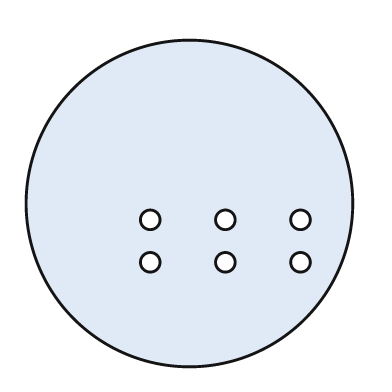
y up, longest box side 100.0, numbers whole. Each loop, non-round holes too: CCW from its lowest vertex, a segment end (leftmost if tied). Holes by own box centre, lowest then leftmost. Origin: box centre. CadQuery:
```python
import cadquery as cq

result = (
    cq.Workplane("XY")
    .moveTo(0.0, 0.0)
    .circle(50.0)
    .moveTo(-12.0, -18.0)
    .circle(3.0)
    .moveTo(11.0, -18.0)
    .circle(3.0)
    .moveTo(34.0, -18.0)
    .circle(3.0)
    .moveTo(-12.0, -5.0)
    .circle(3.0)
    .moveTo(11.0, -5.0)
    .circle(3.0)
    .moveTo(34.0, -5.0)
    .circle(3.0)
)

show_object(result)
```